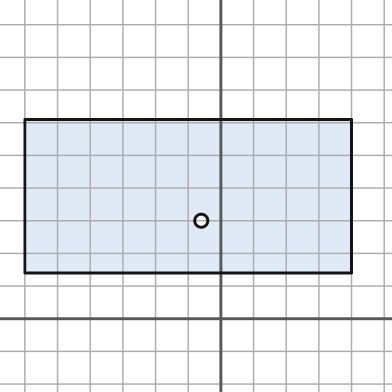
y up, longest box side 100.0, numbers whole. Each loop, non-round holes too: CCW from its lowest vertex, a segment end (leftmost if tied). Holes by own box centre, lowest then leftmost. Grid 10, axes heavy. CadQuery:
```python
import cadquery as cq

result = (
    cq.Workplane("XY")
    .moveTo(-60.0, 14.0)
    .lineTo(40.0, 14.0)
    .lineTo(40.0, 61.0)
    .lineTo(-60.0, 61.0)
    .close()
    .moveTo(-6.0, 30.0)
    .circle(2.0)
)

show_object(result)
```